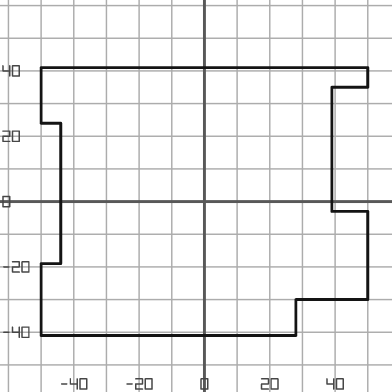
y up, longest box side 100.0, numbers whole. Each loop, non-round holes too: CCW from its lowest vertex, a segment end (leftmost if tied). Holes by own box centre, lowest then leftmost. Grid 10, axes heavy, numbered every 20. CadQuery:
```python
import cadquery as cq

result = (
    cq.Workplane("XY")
    .moveTo(-50.0, -41.0)
    .lineTo(28.0, -41.0)
    .lineTo(28.0, -30.0)
    .lineTo(50.0, -30.0)
    .lineTo(50.0, -3.0)
    .lineTo(39.0, -3.0)
    .lineTo(39.0, 35.0)
    .lineTo(50.0, 35.0)
    .lineTo(50.0, 41.0)
    .lineTo(-50.0, 41.0)
    .lineTo(-50.0, 24.0)
    .lineTo(-44.0, 24.0)
    .lineTo(-44.0, -19.0)
    .lineTo(-50.0, -19.0)
    .close()
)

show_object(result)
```